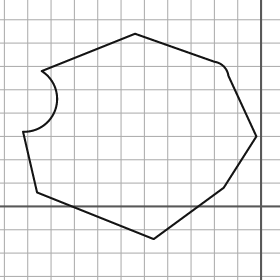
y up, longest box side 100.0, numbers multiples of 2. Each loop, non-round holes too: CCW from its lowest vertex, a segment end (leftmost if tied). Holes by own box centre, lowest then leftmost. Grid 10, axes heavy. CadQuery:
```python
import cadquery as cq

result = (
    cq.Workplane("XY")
    .moveTo(-46.0, -14.0)
    .lineTo(-16.0, 8.0)
    .lineTo(-2.0, 30.0)
    .lineTo(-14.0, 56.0)
    .threePointArc((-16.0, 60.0), (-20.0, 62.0))
    .lineTo(-54.0, 74.0)
    .lineTo(-94.0, 58.0)
    .threePointArc((-88.0, 42.0), (-102.0, 32.0))
    .lineTo(-96.0, 6.0)
    .close()
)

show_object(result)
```